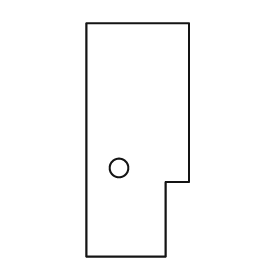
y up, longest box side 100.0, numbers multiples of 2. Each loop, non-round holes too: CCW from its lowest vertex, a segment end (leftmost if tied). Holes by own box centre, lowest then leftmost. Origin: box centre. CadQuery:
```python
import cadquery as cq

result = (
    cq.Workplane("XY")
    .moveTo(-22.0, -50.0)
    .lineTo(12.0, -50.0)
    .lineTo(12.0, -18.0)
    .lineTo(22.0, -18.0)
    .lineTo(22.0, 50.0)
    .lineTo(-22.0, 50.0)
    .close()
    .moveTo(-8.0, -12.0)
    .circle(4.0)
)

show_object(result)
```